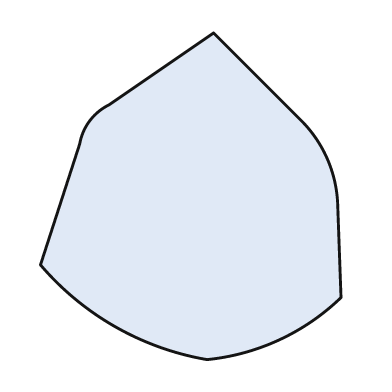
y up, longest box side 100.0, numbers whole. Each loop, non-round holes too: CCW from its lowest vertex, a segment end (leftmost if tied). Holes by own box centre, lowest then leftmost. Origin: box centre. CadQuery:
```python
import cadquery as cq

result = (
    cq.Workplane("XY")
    .moveTo(5.0, -50.0)
    .threePointArc((27.0, -44.0), (46.0, -31.0))
    .lineTo(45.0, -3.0)
    .threePointArc((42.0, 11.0), (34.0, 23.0))
    .lineTo(7.0, 50.0)
    .lineTo(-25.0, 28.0)
    .threePointArc((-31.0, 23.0), (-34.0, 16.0))
    .lineTo(-46.0, -21.0)
    .threePointArc((-23.0, -40.0), (5.0, -50.0))
    .close()
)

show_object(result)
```